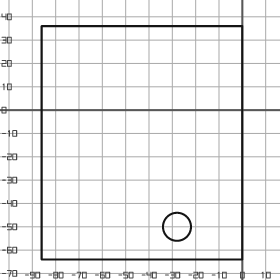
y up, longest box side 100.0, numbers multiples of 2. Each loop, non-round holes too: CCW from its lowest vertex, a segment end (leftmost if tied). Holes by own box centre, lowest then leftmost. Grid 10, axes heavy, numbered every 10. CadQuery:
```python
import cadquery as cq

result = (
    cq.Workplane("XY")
    .moveTo(-86.0, -64.0)
    .lineTo(0.0, -64.0)
    .lineTo(0.0, 36.0)
    .lineTo(-86.0, 36.0)
    .close()
    .moveTo(-28.0, -50.0)
    .circle(6.0)
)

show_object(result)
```